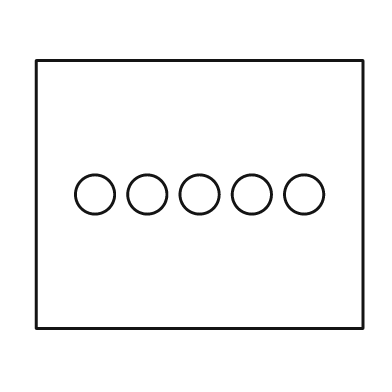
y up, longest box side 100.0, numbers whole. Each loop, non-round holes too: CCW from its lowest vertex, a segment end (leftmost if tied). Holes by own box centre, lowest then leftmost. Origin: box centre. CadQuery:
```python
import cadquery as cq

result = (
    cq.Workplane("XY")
    .moveTo(-50.0, -41.0)
    .lineTo(50.0, -41.0)
    .lineTo(50.0, 41.0)
    .lineTo(-50.0, 41.0)
    .close()
    .moveTo(-32.0, 0.0)
    .circle(6.0)
    .moveTo(-16.0, 0.0)
    .circle(6.0)
    .moveTo(0.0, 0.0)
    .circle(6.0)
    .moveTo(16.0, 0.0)
    .circle(6.0)
    .moveTo(32.0, 0.0)
    .circle(6.0)
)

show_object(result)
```